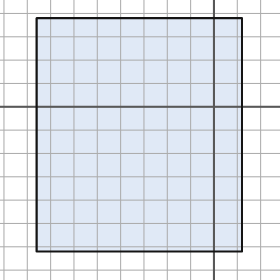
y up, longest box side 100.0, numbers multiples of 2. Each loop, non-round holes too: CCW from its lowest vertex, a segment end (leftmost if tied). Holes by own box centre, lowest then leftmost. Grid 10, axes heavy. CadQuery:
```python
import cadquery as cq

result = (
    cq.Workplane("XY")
    .moveTo(-76.0, -62.0)
    .lineTo(12.0, -62.0)
    .lineTo(12.0, 38.0)
    .lineTo(-76.0, 38.0)
    .close()
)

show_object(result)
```